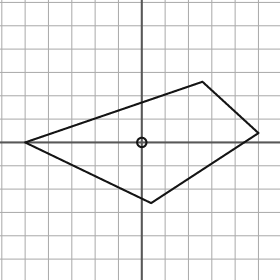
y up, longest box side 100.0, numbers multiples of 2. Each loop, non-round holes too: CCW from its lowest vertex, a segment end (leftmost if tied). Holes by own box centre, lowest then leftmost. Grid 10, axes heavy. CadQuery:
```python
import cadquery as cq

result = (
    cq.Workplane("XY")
    .moveTo(4.0, -26.0)
    .lineTo(50.0, 4.0)
    .lineTo(26.0, 26.0)
    .lineTo(-50.0, 0.0)
    .close()
    .moveTo(0.0, 0.0)
    .circle(2.0)
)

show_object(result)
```